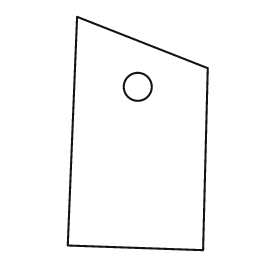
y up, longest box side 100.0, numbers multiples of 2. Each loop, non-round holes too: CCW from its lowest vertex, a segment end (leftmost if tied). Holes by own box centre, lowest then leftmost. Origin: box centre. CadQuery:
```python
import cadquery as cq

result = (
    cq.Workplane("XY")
    .moveTo(28.0, -50.0)
    .lineTo(30.0, 28.0)
    .lineTo(-26.0, 50.0)
    .lineTo(-30.0, -48.0)
    .close()
    .moveTo(0.0, 20.0)
    .circle(6.0)
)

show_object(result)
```